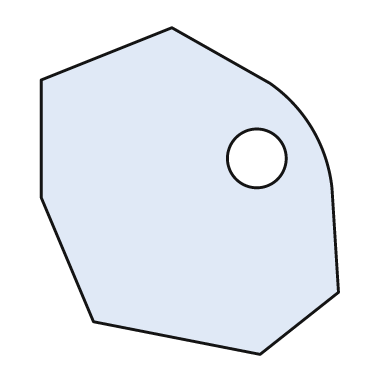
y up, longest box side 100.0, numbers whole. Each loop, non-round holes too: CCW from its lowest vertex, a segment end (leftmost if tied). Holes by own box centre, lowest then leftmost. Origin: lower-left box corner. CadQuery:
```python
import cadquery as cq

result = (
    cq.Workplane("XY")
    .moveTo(67.0, 0.0)
    .lineTo(91.0, 19.0)
    .lineTo(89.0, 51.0)
    .threePointArc((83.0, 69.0), (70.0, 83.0))
    .lineTo(40.0, 100.0)
    .lineTo(0.0, 84.0)
    .lineTo(0.0, 48.0)
    .lineTo(16.0, 10.0)
    .close()
    .moveTo(66.0, 60.0)
    .circle(9.0)
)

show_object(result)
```